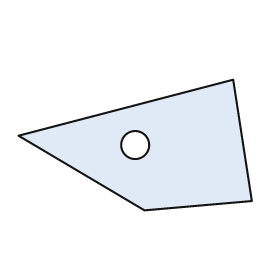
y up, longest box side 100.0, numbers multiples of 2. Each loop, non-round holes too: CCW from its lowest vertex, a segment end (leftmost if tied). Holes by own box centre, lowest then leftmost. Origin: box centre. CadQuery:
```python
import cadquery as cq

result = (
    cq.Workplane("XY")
    .moveTo(4.0, -28.0)
    .lineTo(50.0, -24.0)
    .lineTo(42.0, 28.0)
    .lineTo(-50.0, 4.0)
    .close()
    .moveTo(0.0, 0.0)
    .circle(6.0)
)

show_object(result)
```